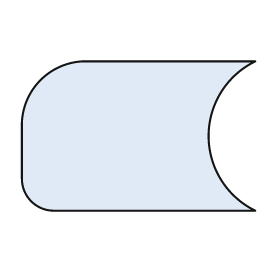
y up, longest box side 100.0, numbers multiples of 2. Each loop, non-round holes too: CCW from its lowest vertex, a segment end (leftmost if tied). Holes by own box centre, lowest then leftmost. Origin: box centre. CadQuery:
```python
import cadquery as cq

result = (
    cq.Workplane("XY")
    .moveTo(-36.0, -32.0)
    .lineTo(50.0, -32.0)
    .threePointArc((30.0, 0.0), (50.0, 32.0))
    .lineTo(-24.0, 32.0)
    .threePointArc((-42.0, 24.0), (-50.0, 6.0))
    .lineTo(-50.0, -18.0)
    .threePointArc((-46.0, -28.0), (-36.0, -32.0))
    .close()
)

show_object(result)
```